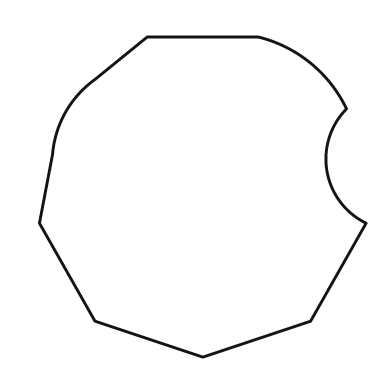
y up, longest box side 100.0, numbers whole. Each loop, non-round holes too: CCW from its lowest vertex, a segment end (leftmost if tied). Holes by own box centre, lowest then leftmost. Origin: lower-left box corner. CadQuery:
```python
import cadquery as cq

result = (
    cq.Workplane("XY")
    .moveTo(50.0, 0.0)
    .lineTo(83.0, 11.0)
    .lineTo(100.0, 41.0)
    .threePointArc((88.0, 57.0), (94.0, 76.0))
    .threePointArc((83.0, 90.0), (67.0, 98.0))
    .lineTo(33.0, 98.0)
    .lineTo(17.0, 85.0)
    .threePointArc((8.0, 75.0), (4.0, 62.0))
    .lineTo(0.0, 41.0)
    .lineTo(17.0, 11.0)
    .close()
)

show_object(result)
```